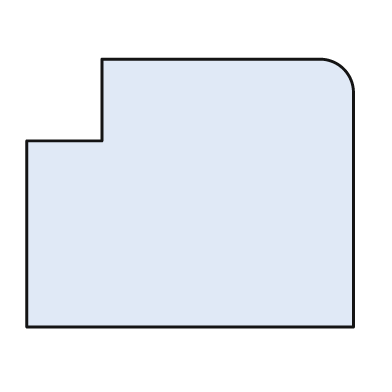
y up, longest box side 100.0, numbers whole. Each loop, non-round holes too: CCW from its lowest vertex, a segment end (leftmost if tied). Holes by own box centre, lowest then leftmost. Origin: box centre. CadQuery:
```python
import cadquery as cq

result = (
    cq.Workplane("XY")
    .moveTo(-50.0, -41.0)
    .lineTo(50.0, -41.0)
    .lineTo(50.0, 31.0)
    .threePointArc((47.0, 38.0), (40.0, 41.0))
    .lineTo(-27.0, 41.0)
    .lineTo(-27.0, 16.0)
    .lineTo(-50.0, 16.0)
    .close()
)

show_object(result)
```